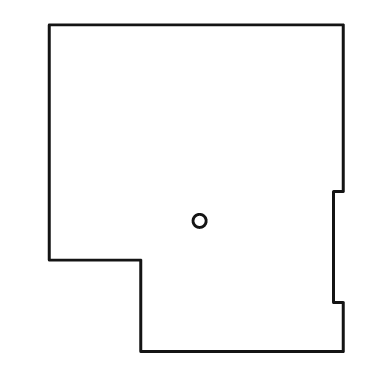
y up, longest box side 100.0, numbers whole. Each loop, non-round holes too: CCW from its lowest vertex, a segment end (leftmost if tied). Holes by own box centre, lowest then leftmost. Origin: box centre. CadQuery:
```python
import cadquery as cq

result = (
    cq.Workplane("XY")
    .moveTo(-17.0, -50.0)
    .lineTo(45.0, -50.0)
    .lineTo(45.0, -35.0)
    .lineTo(42.0, -35.0)
    .lineTo(42.0, -1.0)
    .lineTo(45.0, -1.0)
    .lineTo(45.0, 50.0)
    .lineTo(-45.0, 50.0)
    .lineTo(-45.0, -22.0)
    .lineTo(-17.0, -22.0)
    .close()
    .moveTo(1.0, -10.0)
    .circle(2.0)
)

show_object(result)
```